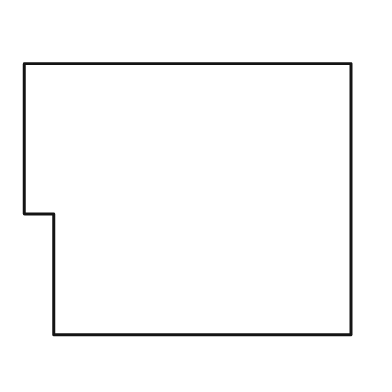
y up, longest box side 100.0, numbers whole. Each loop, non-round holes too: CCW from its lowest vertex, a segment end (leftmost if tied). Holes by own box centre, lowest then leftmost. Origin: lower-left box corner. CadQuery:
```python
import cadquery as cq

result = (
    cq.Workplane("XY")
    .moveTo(9.0, 0.0)
    .lineTo(100.0, 0.0)
    .lineTo(100.0, 83.0)
    .lineTo(0.0, 83.0)
    .lineTo(0.0, 37.0)
    .lineTo(9.0, 37.0)
    .close()
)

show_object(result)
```